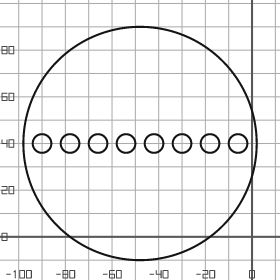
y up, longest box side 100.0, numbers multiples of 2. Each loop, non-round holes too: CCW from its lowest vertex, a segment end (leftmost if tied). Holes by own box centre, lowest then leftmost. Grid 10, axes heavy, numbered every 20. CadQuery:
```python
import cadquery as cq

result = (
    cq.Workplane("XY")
    .moveTo(-48.0, 40.0)
    .circle(50.0)
    .moveTo(-90.0, 40.0)
    .circle(4.0)
    .moveTo(-78.0, 40.0)
    .circle(4.0)
    .moveTo(-66.0, 40.0)
    .circle(4.0)
    .moveTo(-54.0, 40.0)
    .circle(4.0)
    .moveTo(-42.0, 40.0)
    .circle(4.0)
    .moveTo(-30.0, 40.0)
    .circle(4.0)
    .moveTo(-18.0, 40.0)
    .circle(4.0)
    .moveTo(-6.0, 40.0)
    .circle(4.0)
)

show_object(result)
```